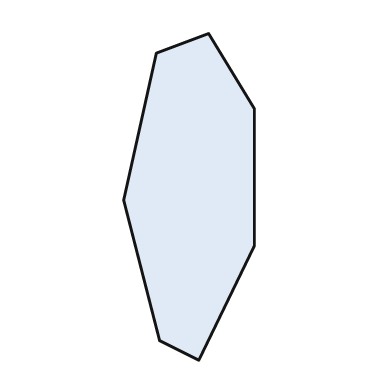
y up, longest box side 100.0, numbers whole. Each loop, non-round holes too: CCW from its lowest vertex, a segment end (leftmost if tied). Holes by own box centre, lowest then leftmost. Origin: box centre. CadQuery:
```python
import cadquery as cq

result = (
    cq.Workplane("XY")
    .moveTo(3.0, -50.0)
    .lineTo(20.0, -15.0)
    .lineTo(20.0, 27.0)
    .lineTo(6.0, 50.0)
    .lineTo(-10.0, 44.0)
    .lineTo(-20.0, -1.0)
    .lineTo(-9.0, -44.0)
    .close()
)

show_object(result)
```